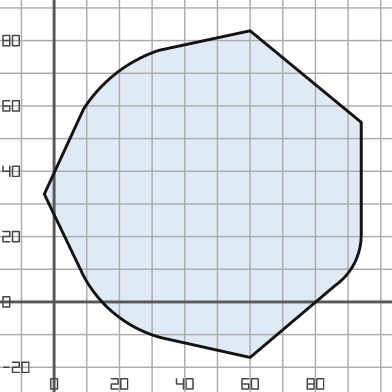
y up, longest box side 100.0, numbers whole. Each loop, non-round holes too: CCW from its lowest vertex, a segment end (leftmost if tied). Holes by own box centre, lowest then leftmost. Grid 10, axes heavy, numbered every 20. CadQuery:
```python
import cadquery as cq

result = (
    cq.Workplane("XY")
    .moveTo(60.0, -17.0)
    .lineTo(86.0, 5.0)
    .threePointArc((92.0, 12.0), (94.0, 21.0))
    .lineTo(94.0, 55.0)
    .lineTo(60.0, 83.0)
    .lineTo(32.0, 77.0)
    .threePointArc((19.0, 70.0), (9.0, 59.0))
    .lineTo(-3.0, 33.0)
    .lineTo(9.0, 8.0)
    .threePointArc((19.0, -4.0), (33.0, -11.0))
    .close()
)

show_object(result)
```